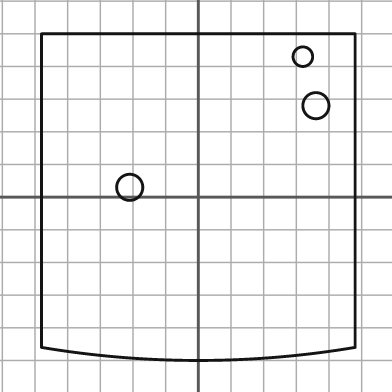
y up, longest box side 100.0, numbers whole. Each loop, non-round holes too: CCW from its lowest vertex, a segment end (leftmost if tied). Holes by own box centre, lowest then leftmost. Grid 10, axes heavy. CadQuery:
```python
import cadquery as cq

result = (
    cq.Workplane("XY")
    .moveTo(-48.0, -46.0)
    .threePointArc((0.0, -50.0), (48.0, -46.0))
    .lineTo(48.0, 50.0)
    .lineTo(-48.0, 50.0)
    .close()
    .moveTo(-21.0, 3.0)
    .circle(4.0)
    .moveTo(36.0, 28.0)
    .circle(4.0)
    .moveTo(32.0, 43.0)
    .circle(3.0)
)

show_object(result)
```